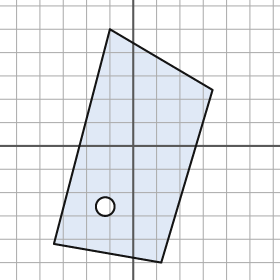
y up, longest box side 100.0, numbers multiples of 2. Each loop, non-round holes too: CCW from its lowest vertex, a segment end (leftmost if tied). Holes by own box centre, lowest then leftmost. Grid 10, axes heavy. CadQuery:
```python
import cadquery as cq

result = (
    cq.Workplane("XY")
    .moveTo(12.0, -50.0)
    .lineTo(34.0, 24.0)
    .lineTo(-10.0, 50.0)
    .lineTo(-34.0, -42.0)
    .close()
    .moveTo(-12.0, -26.0)
    .circle(4.0)
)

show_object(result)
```